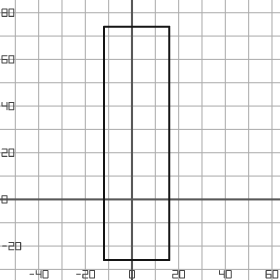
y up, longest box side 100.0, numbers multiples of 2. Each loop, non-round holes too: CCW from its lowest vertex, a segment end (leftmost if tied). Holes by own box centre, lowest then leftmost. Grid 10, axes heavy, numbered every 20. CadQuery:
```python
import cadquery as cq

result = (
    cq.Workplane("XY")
    .moveTo(-12.0, -26.0)
    .lineTo(16.0, -26.0)
    .lineTo(16.0, 74.0)
    .lineTo(-12.0, 74.0)
    .close()
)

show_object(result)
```